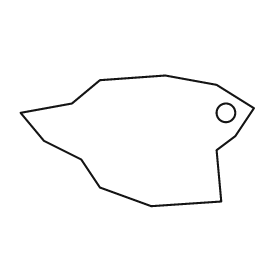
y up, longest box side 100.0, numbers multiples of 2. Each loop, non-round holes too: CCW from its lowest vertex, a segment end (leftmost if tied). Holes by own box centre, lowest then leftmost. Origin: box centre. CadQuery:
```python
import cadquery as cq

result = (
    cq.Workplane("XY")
    .moveTo(6.0, -28.0)
    .lineTo(36.0, -26.0)
    .lineTo(34.0, -4.0)
    .lineTo(42.0, 2.0)
    .lineTo(50.0, 14.0)
    .lineTo(34.0, 24.0)
    .lineTo(12.0, 28.0)
    .lineTo(-16.0, 26.0)
    .lineTo(-28.0, 16.0)
    .lineTo(-50.0, 12.0)
    .lineTo(-40.0, 0.0)
    .lineTo(-24.0, -8.0)
    .lineTo(-16.0, -20.0)
    .close()
    .moveTo(38.0, 12.0)
    .circle(4.0)
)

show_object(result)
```